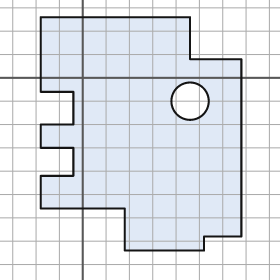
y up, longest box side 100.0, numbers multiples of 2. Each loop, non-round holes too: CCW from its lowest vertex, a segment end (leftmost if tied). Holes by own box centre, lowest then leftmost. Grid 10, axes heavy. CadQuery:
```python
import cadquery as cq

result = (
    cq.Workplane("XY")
    .moveTo(18.0, -74.0)
    .lineTo(52.0, -74.0)
    .lineTo(52.0, -68.0)
    .lineTo(68.0, -68.0)
    .lineTo(68.0, 8.0)
    .lineTo(46.0, 8.0)
    .lineTo(46.0, 26.0)
    .lineTo(-18.0, 26.0)
    .lineTo(-18.0, -6.0)
    .lineTo(-4.0, -6.0)
    .lineTo(-4.0, -20.0)
    .lineTo(-18.0, -20.0)
    .lineTo(-18.0, -30.0)
    .lineTo(-4.0, -30.0)
    .lineTo(-4.0, -42.0)
    .lineTo(-18.0, -42.0)
    .lineTo(-18.0, -56.0)
    .lineTo(18.0, -56.0)
    .close()
    .moveTo(46.0, -10.0)
    .circle(8.0)
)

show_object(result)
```